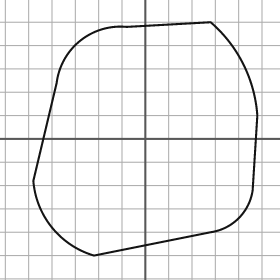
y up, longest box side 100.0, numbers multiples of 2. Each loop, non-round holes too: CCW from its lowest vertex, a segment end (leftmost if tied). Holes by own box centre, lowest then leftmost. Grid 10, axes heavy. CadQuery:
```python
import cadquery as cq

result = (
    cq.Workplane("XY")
    .moveTo(-22.0, -50.0)
    .lineTo(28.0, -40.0)
    .threePointArc((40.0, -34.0), (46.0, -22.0))
    .lineTo(48.0, 10.0)
    .threePointArc((42.0, 32.0), (28.0, 50.0))
    .lineTo(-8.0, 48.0)
    .threePointArc((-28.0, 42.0), (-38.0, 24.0))
    .lineTo(-48.0, -18.0)
    .threePointArc((-40.0, -38.0), (-22.0, -50.0))
    .close()
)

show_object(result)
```